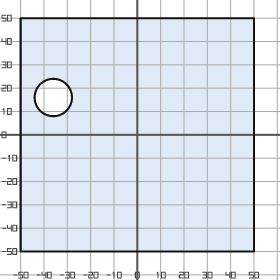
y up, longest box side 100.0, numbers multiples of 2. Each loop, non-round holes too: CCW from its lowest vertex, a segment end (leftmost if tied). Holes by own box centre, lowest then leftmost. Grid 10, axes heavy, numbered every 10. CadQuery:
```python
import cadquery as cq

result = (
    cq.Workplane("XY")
    .moveTo(-50.0, -50.0)
    .lineTo(50.0, -50.0)
    .lineTo(50.0, 50.0)
    .lineTo(-50.0, 50.0)
    .close()
    .moveTo(-36.0, 16.0)
    .circle(8.0)
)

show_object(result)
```